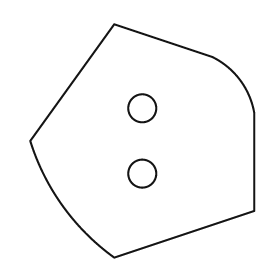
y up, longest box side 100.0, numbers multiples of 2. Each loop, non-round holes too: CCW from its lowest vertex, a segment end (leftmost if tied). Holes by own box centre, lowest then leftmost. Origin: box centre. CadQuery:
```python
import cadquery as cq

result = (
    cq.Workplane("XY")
    .moveTo(-12.0, -50.0)
    .lineTo(48.0, -30.0)
    .lineTo(48.0, 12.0)
    .threePointArc((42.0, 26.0), (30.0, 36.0))
    .lineTo(-12.0, 50.0)
    .lineTo(-48.0, 0.0)
    .threePointArc((-34.0, -28.0), (-12.0, -50.0))
    .close()
    .moveTo(0.0, -14.0)
    .circle(6.0)
    .moveTo(0.0, 14.0)
    .circle(6.0)
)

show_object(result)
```